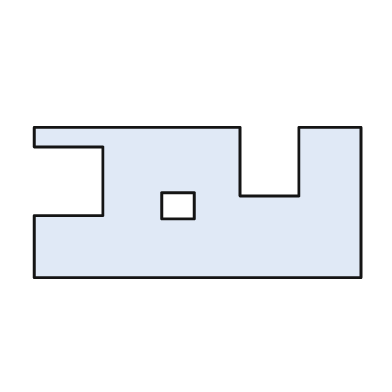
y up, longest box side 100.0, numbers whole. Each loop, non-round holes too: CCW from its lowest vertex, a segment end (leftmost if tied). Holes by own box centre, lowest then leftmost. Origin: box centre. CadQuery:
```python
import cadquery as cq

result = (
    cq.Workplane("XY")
    .moveTo(-50.0, -23.0)
    .lineTo(50.0, -23.0)
    .lineTo(50.0, 23.0)
    .lineTo(31.0, 23.0)
    .lineTo(31.0, 2.0)
    .lineTo(13.0, 2.0)
    .lineTo(13.0, 23.0)
    .lineTo(-50.0, 23.0)
    .lineTo(-50.0, 17.0)
    .lineTo(-29.0, 17.0)
    .lineTo(-29.0, -4.0)
    .lineTo(-50.0, -4.0)
    .close()
    .moveTo(-11.0, -5.0)
    .lineTo(-1.0, -5.0)
    .lineTo(-1.0, 3.0)
    .lineTo(-11.0, 3.0)
    .close()
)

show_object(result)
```